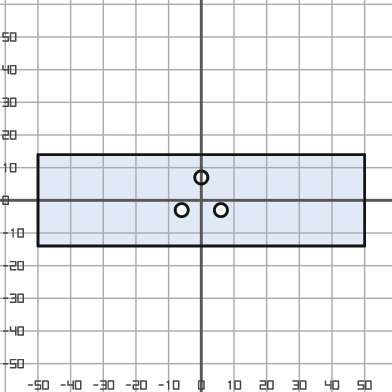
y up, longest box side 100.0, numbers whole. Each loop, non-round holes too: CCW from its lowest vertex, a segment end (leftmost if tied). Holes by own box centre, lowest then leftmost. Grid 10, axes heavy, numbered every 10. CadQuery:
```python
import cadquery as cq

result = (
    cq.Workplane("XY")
    .moveTo(-50.0, -14.0)
    .lineTo(50.0, -14.0)
    .lineTo(50.0, 14.0)
    .lineTo(-50.0, 14.0)
    .close()
    .moveTo(-6.0, -3.0)
    .circle(2.0)
    .moveTo(6.0, -3.0)
    .circle(2.0)
    .moveTo(0.0, 7.0)
    .circle(2.0)
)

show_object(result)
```